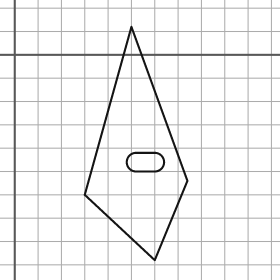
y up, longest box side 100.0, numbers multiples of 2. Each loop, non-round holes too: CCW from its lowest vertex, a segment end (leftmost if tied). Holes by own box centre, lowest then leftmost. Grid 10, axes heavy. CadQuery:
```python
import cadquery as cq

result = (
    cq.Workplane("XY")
    .moveTo(60.0, -88.0)
    .lineTo(74.0, -54.0)
    .lineTo(50.0, 12.0)
    .lineTo(30.0, -60.0)
    .close()
    .moveTo(52.0, -50.0)
    .lineTo(60.0, -50.0)
    .threePointArc((64.0, -46.0), (60.0, -42.0))
    .lineTo(52.0, -42.0)
    .threePointArc((48.0, -46.0), (52.0, -50.0))
    .close()
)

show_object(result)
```